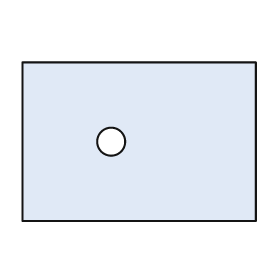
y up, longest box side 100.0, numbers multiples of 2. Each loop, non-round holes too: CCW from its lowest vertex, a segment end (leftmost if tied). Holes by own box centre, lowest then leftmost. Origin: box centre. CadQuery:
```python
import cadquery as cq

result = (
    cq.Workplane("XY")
    .moveTo(-50.0, -34.0)
    .lineTo(50.0, -34.0)
    .lineTo(50.0, 34.0)
    .lineTo(-50.0, 34.0)
    .close()
    .moveTo(-12.0, 0.0)
    .circle(6.0)
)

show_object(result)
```